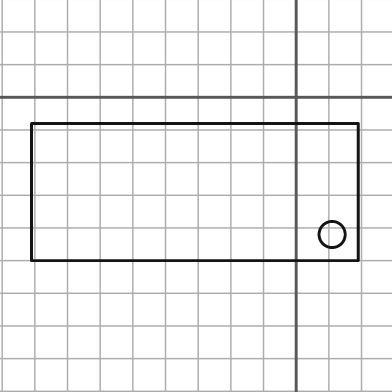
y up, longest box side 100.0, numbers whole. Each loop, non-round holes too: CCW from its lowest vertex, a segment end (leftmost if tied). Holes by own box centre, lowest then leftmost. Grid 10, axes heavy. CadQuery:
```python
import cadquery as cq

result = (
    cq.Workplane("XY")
    .moveTo(-81.0, -50.0)
    .lineTo(19.0, -50.0)
    .lineTo(19.0, -8.0)
    .lineTo(-81.0, -8.0)
    .close()
    .moveTo(11.0, -42.0)
    .circle(4.0)
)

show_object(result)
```